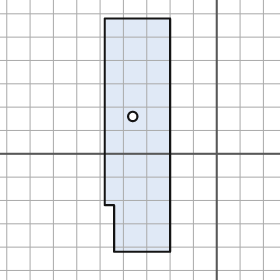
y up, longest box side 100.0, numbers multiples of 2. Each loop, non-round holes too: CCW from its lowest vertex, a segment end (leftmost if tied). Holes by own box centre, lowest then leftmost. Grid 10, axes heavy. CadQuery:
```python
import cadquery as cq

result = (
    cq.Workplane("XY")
    .moveTo(-44.0, -42.0)
    .lineTo(-20.0, -42.0)
    .lineTo(-20.0, 58.0)
    .lineTo(-48.0, 58.0)
    .lineTo(-48.0, -22.0)
    .lineTo(-44.0, -22.0)
    .close()
    .moveTo(-36.0, 16.0)
    .circle(2.0)
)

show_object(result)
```